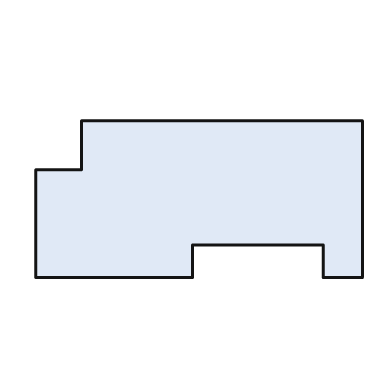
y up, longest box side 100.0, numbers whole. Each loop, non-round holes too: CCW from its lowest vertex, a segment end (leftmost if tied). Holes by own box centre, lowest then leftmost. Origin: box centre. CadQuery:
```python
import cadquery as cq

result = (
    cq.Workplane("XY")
    .moveTo(-50.0, -24.0)
    .lineTo(-2.0, -24.0)
    .lineTo(-2.0, -14.0)
    .lineTo(38.0, -14.0)
    .lineTo(38.0, -24.0)
    .lineTo(50.0, -24.0)
    .lineTo(50.0, 24.0)
    .lineTo(-36.0, 24.0)
    .lineTo(-36.0, 9.0)
    .lineTo(-50.0, 9.0)
    .close()
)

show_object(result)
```